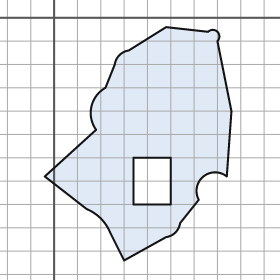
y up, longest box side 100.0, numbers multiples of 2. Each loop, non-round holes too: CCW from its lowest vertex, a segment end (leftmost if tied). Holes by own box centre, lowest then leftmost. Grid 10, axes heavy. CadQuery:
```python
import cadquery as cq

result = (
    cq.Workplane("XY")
    .moveTo(30.0, -104.0)
    .lineTo(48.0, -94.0)
    .threePointArc((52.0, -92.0), (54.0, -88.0))
    .lineTo(62.0, -78.0)
    .threePointArc((64.0, -68.0), (74.0, -68.0))
    .lineTo(76.0, -40.0)
    .lineTo(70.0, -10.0)
    .threePointArc((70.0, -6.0), (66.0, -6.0))
    .lineTo(48.0, -4.0)
    .lineTo(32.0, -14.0)
    .threePointArc((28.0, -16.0), (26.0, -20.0))
    .lineTo(22.0, -30.0)
    .threePointArc((16.0, -38.0), (18.0, -48.0))
    .lineTo(-4.0, -68.0)
    .lineTo(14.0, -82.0)
    .threePointArc((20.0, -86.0), (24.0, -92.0))
    .close()
    .moveTo(34.0, -80.0)
    .lineTo(50.0, -80.0)
    .lineTo(50.0, -60.0)
    .lineTo(34.0, -60.0)
    .close()
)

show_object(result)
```